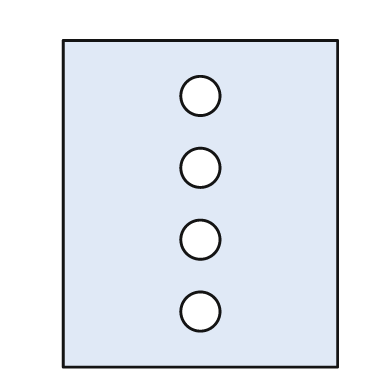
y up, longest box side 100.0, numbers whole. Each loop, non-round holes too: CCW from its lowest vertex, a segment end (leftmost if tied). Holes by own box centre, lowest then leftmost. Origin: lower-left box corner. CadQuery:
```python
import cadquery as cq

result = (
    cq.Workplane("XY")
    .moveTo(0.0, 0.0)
    .lineTo(84.0, 0.0)
    .lineTo(84.0, 100.0)
    .lineTo(0.0, 100.0)
    .close()
    .moveTo(42.0, 17.0)
    .circle(6.0)
    .moveTo(42.0, 39.0)
    .circle(6.0)
    .moveTo(42.0, 61.0)
    .circle(6.0)
    .moveTo(42.0, 83.0)
    .circle(6.0)
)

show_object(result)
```